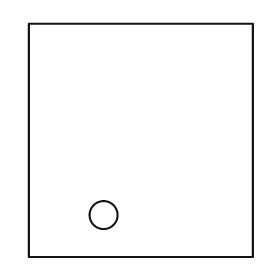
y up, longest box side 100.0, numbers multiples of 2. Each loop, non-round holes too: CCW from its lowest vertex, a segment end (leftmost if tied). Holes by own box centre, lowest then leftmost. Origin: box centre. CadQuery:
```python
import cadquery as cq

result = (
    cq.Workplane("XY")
    .moveTo(-48.0, -50.0)
    .lineTo(48.0, -50.0)
    .lineTo(48.0, 50.0)
    .lineTo(-48.0, 50.0)
    .close()
    .moveTo(-16.0, -32.0)
    .circle(6.0)
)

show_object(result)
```